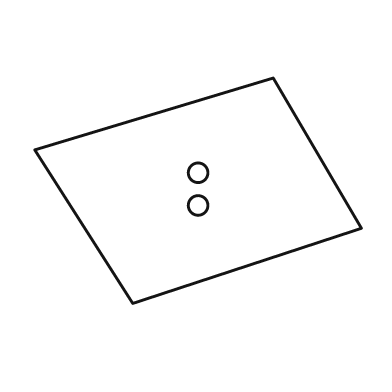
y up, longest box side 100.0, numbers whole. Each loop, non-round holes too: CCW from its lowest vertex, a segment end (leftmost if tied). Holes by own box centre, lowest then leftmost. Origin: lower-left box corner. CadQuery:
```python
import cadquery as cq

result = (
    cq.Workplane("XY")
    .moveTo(30.0, 0.0)
    .lineTo(100.0, 23.0)
    .lineTo(73.0, 69.0)
    .lineTo(0.0, 47.0)
    .close()
    .moveTo(50.0, 30.0)
    .circle(3.0)
    .moveTo(50.0, 40.0)
    .circle(3.0)
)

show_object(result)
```